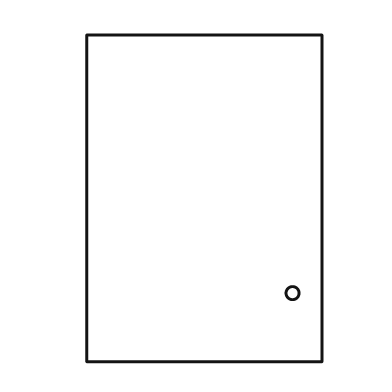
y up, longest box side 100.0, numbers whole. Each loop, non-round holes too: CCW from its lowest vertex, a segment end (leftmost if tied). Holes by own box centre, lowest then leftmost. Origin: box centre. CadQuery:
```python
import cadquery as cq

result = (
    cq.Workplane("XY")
    .moveTo(-36.0, -50.0)
    .lineTo(36.0, -50.0)
    .lineTo(36.0, 50.0)
    .lineTo(-36.0, 50.0)
    .close()
    .moveTo(27.0, -29.0)
    .circle(2.0)
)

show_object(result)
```